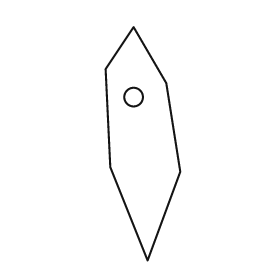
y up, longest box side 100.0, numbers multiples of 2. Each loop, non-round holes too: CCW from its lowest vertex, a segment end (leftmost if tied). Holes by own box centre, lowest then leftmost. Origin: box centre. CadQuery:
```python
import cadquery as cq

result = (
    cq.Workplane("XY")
    .moveTo(2.0, -50.0)
    .lineTo(16.0, -12.0)
    .lineTo(10.0, 26.0)
    .lineTo(-4.0, 50.0)
    .lineTo(-16.0, 32.0)
    .lineTo(-14.0, -10.0)
    .close()
    .moveTo(-4.0, 20.0)
    .circle(4.0)
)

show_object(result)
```